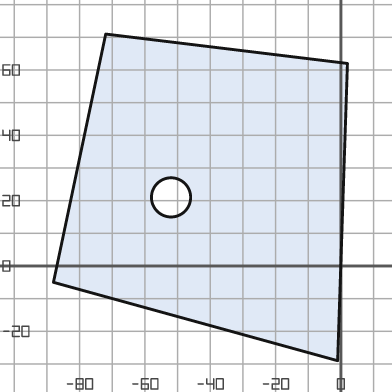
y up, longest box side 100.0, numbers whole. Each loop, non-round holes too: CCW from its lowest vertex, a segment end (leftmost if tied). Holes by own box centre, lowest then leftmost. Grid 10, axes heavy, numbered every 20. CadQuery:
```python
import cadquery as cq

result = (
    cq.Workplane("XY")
    .moveTo(-1.0, -29.0)
    .lineTo(2.0, 62.0)
    .lineTo(-72.0, 71.0)
    .lineTo(-88.0, -5.0)
    .close()
    .moveTo(-52.0, 21.0)
    .circle(6.0)
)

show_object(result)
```